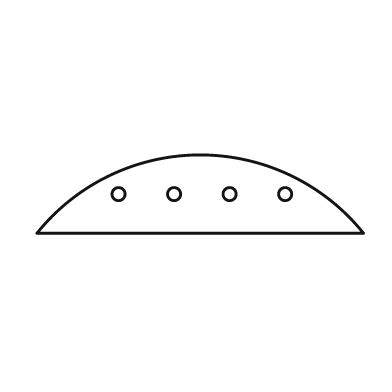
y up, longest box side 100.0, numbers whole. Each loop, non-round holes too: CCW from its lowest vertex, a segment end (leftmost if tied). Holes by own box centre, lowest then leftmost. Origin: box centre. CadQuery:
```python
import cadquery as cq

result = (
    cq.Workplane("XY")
    .moveTo(-50.0, -12.0)
    .lineTo(50.0, -12.0)
    .threePointArc((0.0, 12.0), (-50.0, -12.0))
    .close()
    .moveTo(-25.0, 0.0)
    .circle(2.0)
    .moveTo(-8.0, 0.0)
    .circle(2.0)
    .moveTo(9.0, 0.0)
    .circle(2.0)
    .moveTo(26.0, 0.0)
    .circle(2.0)
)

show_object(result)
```